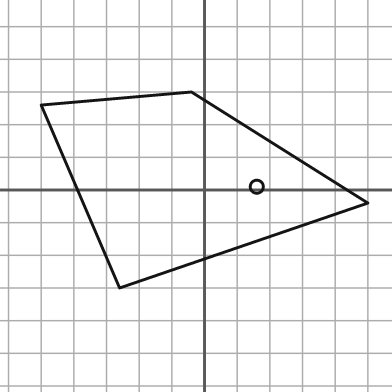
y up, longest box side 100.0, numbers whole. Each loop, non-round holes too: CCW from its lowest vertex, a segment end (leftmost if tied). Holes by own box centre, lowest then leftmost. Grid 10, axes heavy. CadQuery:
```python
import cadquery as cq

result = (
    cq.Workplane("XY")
    .moveTo(-26.0, -30.0)
    .lineTo(50.0, -4.0)
    .lineTo(-4.0, 30.0)
    .lineTo(-50.0, 26.0)
    .close()
    .moveTo(16.0, 1.0)
    .circle(2.0)
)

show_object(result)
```